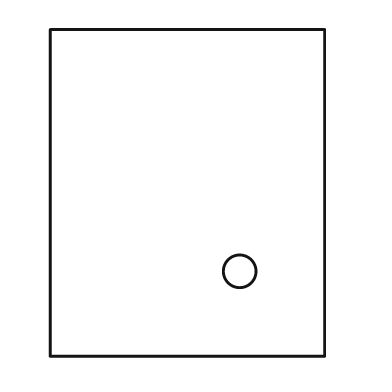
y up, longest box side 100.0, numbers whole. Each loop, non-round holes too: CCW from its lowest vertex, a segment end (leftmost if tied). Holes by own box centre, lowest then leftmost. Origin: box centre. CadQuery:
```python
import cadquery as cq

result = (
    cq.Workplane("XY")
    .moveTo(-42.0, -50.0)
    .lineTo(42.0, -50.0)
    .lineTo(42.0, 50.0)
    .lineTo(-42.0, 50.0)
    .close()
    .moveTo(16.0, -24.0)
    .circle(5.0)
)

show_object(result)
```